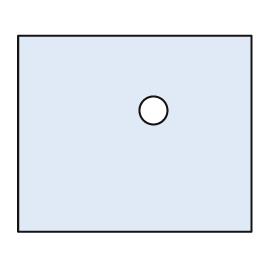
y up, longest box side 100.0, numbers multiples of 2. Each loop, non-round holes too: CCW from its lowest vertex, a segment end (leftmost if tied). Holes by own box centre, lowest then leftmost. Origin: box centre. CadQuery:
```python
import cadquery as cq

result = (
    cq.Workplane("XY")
    .moveTo(-50.0, -42.0)
    .lineTo(50.0, -42.0)
    .lineTo(50.0, 42.0)
    .lineTo(-50.0, 42.0)
    .close()
    .moveTo(8.0, 10.0)
    .circle(6.0)
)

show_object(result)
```